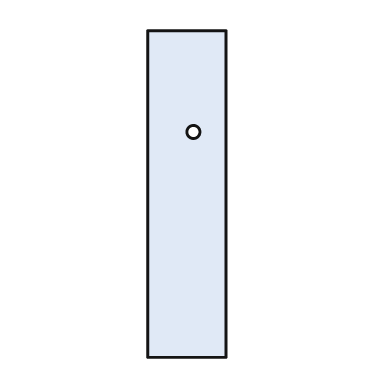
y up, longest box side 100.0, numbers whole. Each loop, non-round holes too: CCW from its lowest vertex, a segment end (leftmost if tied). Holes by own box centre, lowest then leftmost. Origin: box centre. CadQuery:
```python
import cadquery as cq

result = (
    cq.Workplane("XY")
    .moveTo(-12.0, -50.0)
    .lineTo(12.0, -50.0)
    .lineTo(12.0, 50.0)
    .lineTo(-12.0, 50.0)
    .close()
    .moveTo(2.0, 19.0)
    .circle(2.0)
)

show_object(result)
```